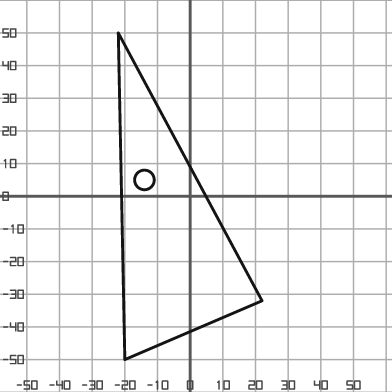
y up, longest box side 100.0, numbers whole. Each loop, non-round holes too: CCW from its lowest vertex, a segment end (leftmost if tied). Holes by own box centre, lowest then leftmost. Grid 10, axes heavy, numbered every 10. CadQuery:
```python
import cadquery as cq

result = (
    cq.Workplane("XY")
    .moveTo(-20.0, -50.0)
    .lineTo(22.0, -32.0)
    .lineTo(-22.0, 50.0)
    .close()
    .moveTo(-14.0, 5.0)
    .circle(3.0)
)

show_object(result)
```